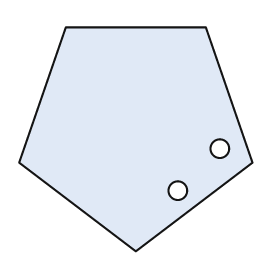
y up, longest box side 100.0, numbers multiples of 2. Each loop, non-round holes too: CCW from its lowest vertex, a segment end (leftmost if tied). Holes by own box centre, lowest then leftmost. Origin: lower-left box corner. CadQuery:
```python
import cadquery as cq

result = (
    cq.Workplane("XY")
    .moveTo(50.0, 0.0)
    .lineTo(100.0, 38.0)
    .lineTo(80.0, 96.0)
    .lineTo(20.0, 96.0)
    .lineTo(0.0, 38.0)
    .close()
    .moveTo(68.0, 26.0)
    .circle(4.0)
    .moveTo(86.0, 44.0)
    .circle(4.0)
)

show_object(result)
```